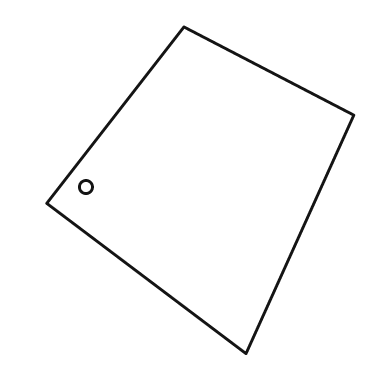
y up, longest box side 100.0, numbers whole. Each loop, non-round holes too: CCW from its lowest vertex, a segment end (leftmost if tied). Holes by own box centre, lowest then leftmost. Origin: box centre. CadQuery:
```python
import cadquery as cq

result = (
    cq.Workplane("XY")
    .moveTo(14.0, -50.0)
    .lineTo(47.0, 23.0)
    .lineTo(-5.0, 50.0)
    .lineTo(-47.0, -4.0)
    .close()
    .moveTo(-35.0, 1.0)
    .circle(2.0)
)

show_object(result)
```